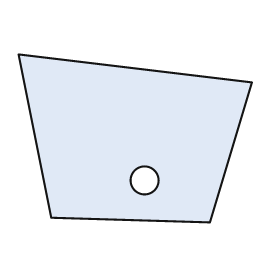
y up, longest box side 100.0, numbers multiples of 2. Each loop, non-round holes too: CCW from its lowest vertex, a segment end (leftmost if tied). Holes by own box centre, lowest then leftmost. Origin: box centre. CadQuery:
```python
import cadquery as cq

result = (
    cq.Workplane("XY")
    .moveTo(32.0, -36.0)
    .lineTo(50.0, 24.0)
    .lineTo(-50.0, 36.0)
    .lineTo(-36.0, -34.0)
    .close()
    .moveTo(4.0, -18.0)
    .circle(6.0)
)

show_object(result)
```